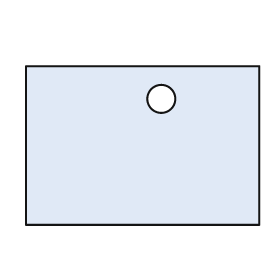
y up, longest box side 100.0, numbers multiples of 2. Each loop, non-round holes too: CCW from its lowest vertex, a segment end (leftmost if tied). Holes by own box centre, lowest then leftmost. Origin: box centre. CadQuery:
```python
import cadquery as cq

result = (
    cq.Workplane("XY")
    .moveTo(-50.0, -34.0)
    .lineTo(50.0, -34.0)
    .lineTo(50.0, 34.0)
    .lineTo(-50.0, 34.0)
    .close()
    .moveTo(8.0, 20.0)
    .circle(6.0)
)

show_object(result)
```